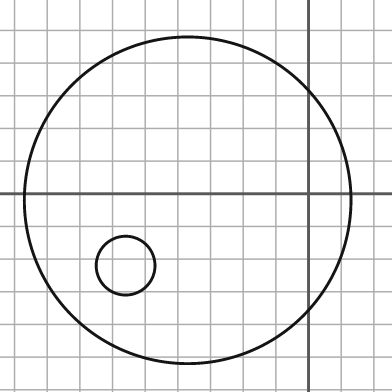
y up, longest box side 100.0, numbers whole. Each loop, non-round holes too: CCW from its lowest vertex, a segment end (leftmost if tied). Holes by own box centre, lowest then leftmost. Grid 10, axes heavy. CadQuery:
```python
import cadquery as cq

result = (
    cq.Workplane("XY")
    .moveTo(-37.0, -2.0)
    .circle(50.0)
    .moveTo(-56.0, -22.0)
    .circle(9.0)
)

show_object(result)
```